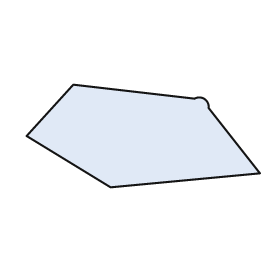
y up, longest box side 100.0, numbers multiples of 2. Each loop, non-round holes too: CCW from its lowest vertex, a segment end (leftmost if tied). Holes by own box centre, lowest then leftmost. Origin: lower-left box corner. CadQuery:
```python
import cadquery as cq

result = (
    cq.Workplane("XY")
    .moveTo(36.0, 0.0)
    .lineTo(100.0, 6.0)
    .lineTo(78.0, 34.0)
    .threePointArc((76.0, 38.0), (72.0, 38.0))
    .lineTo(20.0, 44.0)
    .lineTo(0.0, 22.0)
    .close()
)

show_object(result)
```